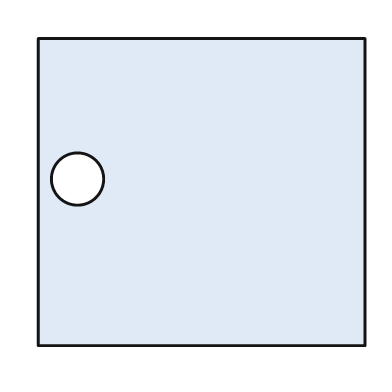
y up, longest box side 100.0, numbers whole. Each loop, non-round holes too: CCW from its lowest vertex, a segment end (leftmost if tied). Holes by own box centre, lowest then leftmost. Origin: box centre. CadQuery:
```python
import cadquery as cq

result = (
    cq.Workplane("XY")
    .moveTo(-50.0, -47.0)
    .lineTo(50.0, -47.0)
    .lineTo(50.0, 47.0)
    .lineTo(-50.0, 47.0)
    .close()
    .moveTo(-38.0, 4.0)
    .circle(8.0)
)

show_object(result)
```